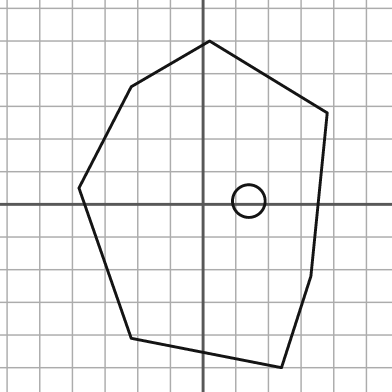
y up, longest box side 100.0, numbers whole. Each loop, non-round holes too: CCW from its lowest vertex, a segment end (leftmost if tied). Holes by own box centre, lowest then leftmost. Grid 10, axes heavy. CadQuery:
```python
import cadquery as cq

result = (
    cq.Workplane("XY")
    .moveTo(24.0, -50.0)
    .lineTo(33.0, -22.0)
    .lineTo(38.0, 28.0)
    .lineTo(2.0, 50.0)
    .lineTo(-22.0, 36.0)
    .lineTo(-38.0, 5.0)
    .lineTo(-22.0, -41.0)
    .close()
    .moveTo(14.0, 1.0)
    .circle(5.0)
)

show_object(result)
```